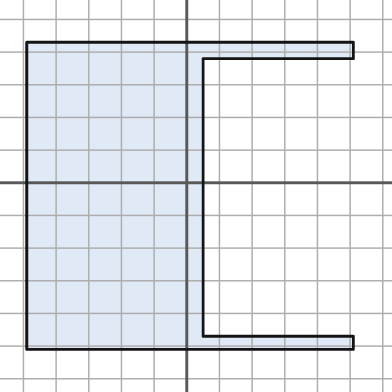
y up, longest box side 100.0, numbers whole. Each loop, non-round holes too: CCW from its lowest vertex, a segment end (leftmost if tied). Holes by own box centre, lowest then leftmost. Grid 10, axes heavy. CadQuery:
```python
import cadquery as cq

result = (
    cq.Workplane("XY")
    .moveTo(-49.0, -51.0)
    .lineTo(51.0, -51.0)
    .lineTo(51.0, -47.0)
    .lineTo(5.0, -47.0)
    .lineTo(5.0, 38.0)
    .lineTo(51.0, 38.0)
    .lineTo(51.0, 43.0)
    .lineTo(-49.0, 43.0)
    .close()
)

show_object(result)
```